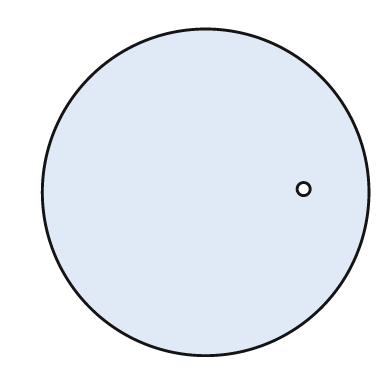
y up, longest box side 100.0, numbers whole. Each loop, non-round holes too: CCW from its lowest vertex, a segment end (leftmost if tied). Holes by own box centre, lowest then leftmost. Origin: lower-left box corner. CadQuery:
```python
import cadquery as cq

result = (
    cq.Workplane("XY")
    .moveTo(50.0, 50.0)
    .circle(50.0)
    .moveTo(80.0, 51.0)
    .circle(2.0)
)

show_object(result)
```